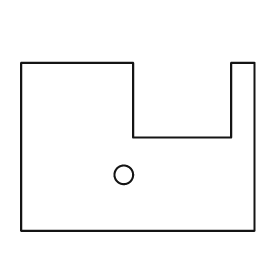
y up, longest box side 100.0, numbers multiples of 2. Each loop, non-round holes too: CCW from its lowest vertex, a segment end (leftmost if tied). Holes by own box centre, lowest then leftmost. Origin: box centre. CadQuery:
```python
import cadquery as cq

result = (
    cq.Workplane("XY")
    .moveTo(-50.0, -36.0)
    .lineTo(50.0, -36.0)
    .lineTo(50.0, 36.0)
    .lineTo(40.0, 36.0)
    .lineTo(40.0, 4.0)
    .lineTo(-2.0, 4.0)
    .lineTo(-2.0, 36.0)
    .lineTo(-50.0, 36.0)
    .close()
    .moveTo(-6.0, -12.0)
    .circle(4.0)
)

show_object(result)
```